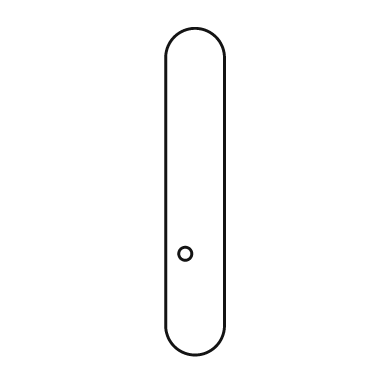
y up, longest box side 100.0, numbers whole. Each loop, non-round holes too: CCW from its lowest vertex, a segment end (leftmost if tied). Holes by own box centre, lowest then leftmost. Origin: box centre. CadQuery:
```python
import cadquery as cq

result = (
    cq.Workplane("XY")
    .moveTo(-9.0, -41.0)
    .threePointArc((0.0, -50.0), (9.0, -41.0))
    .lineTo(9.0, 41.0)
    .threePointArc((0.0, 50.0), (-9.0, 41.0))
    .close()
    .moveTo(-3.0, -19.0)
    .circle(2.0)
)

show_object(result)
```